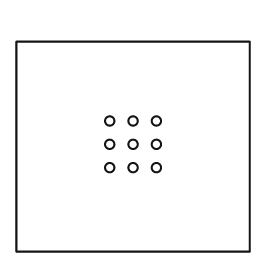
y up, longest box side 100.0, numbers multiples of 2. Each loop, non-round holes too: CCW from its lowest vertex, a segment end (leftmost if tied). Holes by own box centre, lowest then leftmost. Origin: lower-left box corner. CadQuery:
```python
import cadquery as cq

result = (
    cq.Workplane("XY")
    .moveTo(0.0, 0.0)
    .lineTo(100.0, 0.0)
    .lineTo(100.0, 90.0)
    .lineTo(0.0, 90.0)
    .close()
    .moveTo(40.0, 36.0)
    .circle(2.0)
    .moveTo(50.0, 36.0)
    .circle(2.0)
    .moveTo(60.0, 36.0)
    .circle(2.0)
    .moveTo(40.0, 46.0)
    .circle(2.0)
    .moveTo(50.0, 46.0)
    .circle(2.0)
    .moveTo(60.0, 46.0)
    .circle(2.0)
    .moveTo(40.0, 56.0)
    .circle(2.0)
    .moveTo(50.0, 56.0)
    .circle(2.0)
    .moveTo(60.0, 56.0)
    .circle(2.0)
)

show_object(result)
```